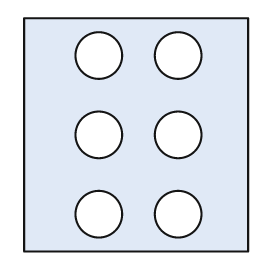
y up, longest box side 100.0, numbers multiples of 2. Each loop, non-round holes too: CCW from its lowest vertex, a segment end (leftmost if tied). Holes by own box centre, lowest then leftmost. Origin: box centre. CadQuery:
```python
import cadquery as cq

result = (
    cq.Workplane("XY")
    .moveTo(-48.0, -50.0)
    .lineTo(48.0, -50.0)
    .lineTo(48.0, 50.0)
    .lineTo(-48.0, 50.0)
    .close()
    .moveTo(-16.0, -34.0)
    .circle(10.0)
    .moveTo(18.0, -34.0)
    .circle(10.0)
    .moveTo(-16.0, 0.0)
    .circle(10.0)
    .moveTo(18.0, 0.0)
    .circle(10.0)
    .moveTo(-16.0, 34.0)
    .circle(10.0)
    .moveTo(18.0, 34.0)
    .circle(10.0)
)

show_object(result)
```